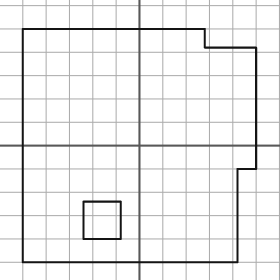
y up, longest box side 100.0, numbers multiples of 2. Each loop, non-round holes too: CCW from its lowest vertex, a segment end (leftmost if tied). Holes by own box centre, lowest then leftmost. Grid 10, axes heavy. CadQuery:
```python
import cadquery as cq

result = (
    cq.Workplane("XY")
    .moveTo(-50.0, -50.0)
    .lineTo(42.0, -50.0)
    .lineTo(42.0, -10.0)
    .lineTo(50.0, -10.0)
    .lineTo(50.0, 42.0)
    .lineTo(28.0, 42.0)
    .lineTo(28.0, 50.0)
    .lineTo(-50.0, 50.0)
    .close()
    .moveTo(-24.0, -40.0)
    .lineTo(-8.0, -40.0)
    .lineTo(-8.0, -24.0)
    .lineTo(-24.0, -24.0)
    .close()
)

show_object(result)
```